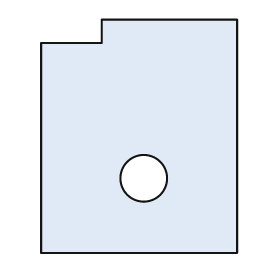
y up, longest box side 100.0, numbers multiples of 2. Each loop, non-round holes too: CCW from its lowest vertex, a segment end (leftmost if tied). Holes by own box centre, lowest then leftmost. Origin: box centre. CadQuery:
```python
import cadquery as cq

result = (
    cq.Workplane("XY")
    .moveTo(-42.0, -50.0)
    .lineTo(42.0, -50.0)
    .lineTo(42.0, 50.0)
    .lineTo(-16.0, 50.0)
    .lineTo(-16.0, 40.0)
    .lineTo(-42.0, 40.0)
    .close()
    .moveTo(2.0, -18.0)
    .circle(10.0)
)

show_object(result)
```